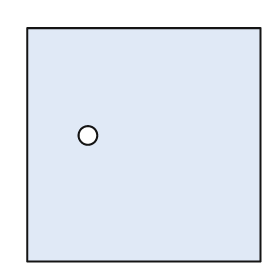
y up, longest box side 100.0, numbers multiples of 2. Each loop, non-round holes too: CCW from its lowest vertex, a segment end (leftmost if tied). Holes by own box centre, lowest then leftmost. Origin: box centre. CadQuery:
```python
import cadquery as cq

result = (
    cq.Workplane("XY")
    .moveTo(-50.0, -50.0)
    .lineTo(50.0, -50.0)
    .lineTo(50.0, 50.0)
    .lineTo(-50.0, 50.0)
    .close()
    .moveTo(-24.0, 4.0)
    .circle(4.0)
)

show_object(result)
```